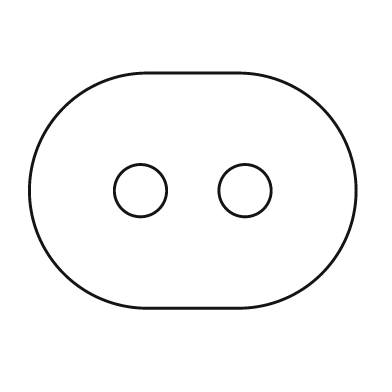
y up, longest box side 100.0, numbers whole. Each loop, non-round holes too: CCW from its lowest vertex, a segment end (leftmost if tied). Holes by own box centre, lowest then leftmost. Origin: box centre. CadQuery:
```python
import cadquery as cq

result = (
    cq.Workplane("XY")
    .moveTo(-14.0, -36.0)
    .lineTo(14.0, -36.0)
    .threePointArc((50.0, 0.0), (14.0, 36.0))
    .lineTo(-14.0, 36.0)
    .threePointArc((-50.0, 0.0), (-14.0, -36.0))
    .close()
    .moveTo(-16.0, 0.0)
    .circle(8.0)
    .moveTo(16.0, 0.0)
    .circle(8.0)
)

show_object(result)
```